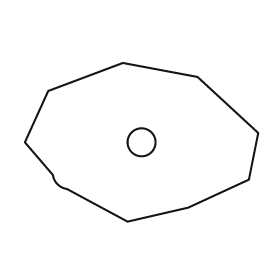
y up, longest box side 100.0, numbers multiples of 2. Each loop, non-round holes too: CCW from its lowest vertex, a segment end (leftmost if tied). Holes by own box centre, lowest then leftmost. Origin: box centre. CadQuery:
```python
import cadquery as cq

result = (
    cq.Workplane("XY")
    .moveTo(-6.0, -34.0)
    .lineTo(20.0, -28.0)
    .lineTo(46.0, -16.0)
    .lineTo(50.0, 4.0)
    .lineTo(24.0, 28.0)
    .lineTo(-8.0, 34.0)
    .lineTo(-40.0, 22.0)
    .lineTo(-50.0, 0.0)
    .lineTo(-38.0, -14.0)
    .threePointArc((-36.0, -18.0), (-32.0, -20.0))
    .close()
    .moveTo(0.0, 0.0)
    .circle(6.0)
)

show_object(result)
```